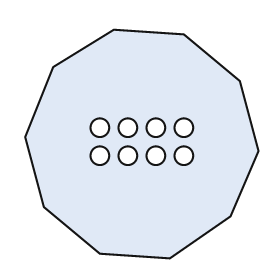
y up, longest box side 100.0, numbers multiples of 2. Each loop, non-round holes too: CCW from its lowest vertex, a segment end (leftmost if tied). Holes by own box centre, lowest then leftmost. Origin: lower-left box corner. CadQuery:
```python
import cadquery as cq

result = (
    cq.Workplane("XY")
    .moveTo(62.0, 0.0)
    .lineTo(88.0, 18.0)
    .lineTo(100.0, 46.0)
    .lineTo(92.0, 76.0)
    .lineTo(68.0, 96.0)
    .lineTo(38.0, 98.0)
    .lineTo(12.0, 82.0)
    .lineTo(0.0, 52.0)
    .lineTo(8.0, 22.0)
    .lineTo(32.0, 2.0)
    .close()
    .moveTo(32.0, 44.0)
    .circle(4.0)
    .moveTo(44.0, 44.0)
    .circle(4.0)
    .moveTo(56.0, 44.0)
    .circle(4.0)
    .moveTo(68.0, 44.0)
    .circle(4.0)
    .moveTo(32.0, 56.0)
    .circle(4.0)
    .moveTo(44.0, 56.0)
    .circle(4.0)
    .moveTo(56.0, 56.0)
    .circle(4.0)
    .moveTo(68.0, 56.0)
    .circle(4.0)
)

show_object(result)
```